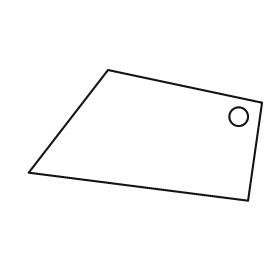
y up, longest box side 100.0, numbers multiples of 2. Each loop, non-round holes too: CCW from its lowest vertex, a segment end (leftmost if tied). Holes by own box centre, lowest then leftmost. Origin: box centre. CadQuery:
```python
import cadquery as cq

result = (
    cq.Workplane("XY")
    .moveTo(44.0, -28.0)
    .lineTo(50.0, 14.0)
    .lineTo(-16.0, 28.0)
    .lineTo(-50.0, -16.0)
    .close()
    .moveTo(40.0, 8.0)
    .circle(4.0)
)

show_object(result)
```